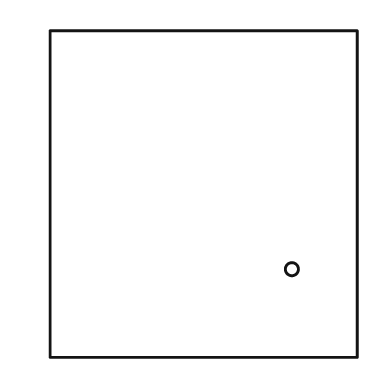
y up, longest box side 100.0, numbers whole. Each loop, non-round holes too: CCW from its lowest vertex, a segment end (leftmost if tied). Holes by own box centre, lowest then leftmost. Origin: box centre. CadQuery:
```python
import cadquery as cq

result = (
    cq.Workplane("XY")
    .moveTo(-47.0, -50.0)
    .lineTo(47.0, -50.0)
    .lineTo(47.0, 50.0)
    .lineTo(-47.0, 50.0)
    .close()
    .moveTo(27.0, -23.0)
    .circle(2.0)
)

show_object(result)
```